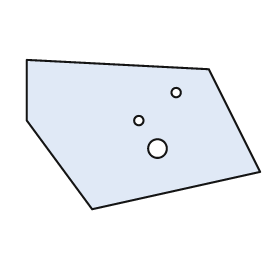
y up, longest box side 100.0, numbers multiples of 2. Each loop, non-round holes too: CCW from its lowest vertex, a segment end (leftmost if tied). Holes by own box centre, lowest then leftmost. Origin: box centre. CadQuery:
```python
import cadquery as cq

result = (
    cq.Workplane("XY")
    .moveTo(-22.0, -32.0)
    .lineTo(50.0, -16.0)
    .lineTo(28.0, 28.0)
    .lineTo(-50.0, 32.0)
    .lineTo(-50.0, 6.0)
    .close()
    .moveTo(6.0, -6.0)
    .circle(4.0)
    .moveTo(-2.0, 6.0)
    .circle(2.0)
    .moveTo(14.0, 18.0)
    .circle(2.0)
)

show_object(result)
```